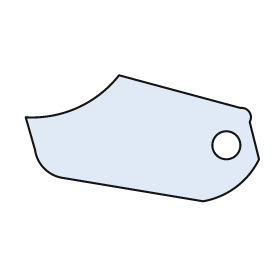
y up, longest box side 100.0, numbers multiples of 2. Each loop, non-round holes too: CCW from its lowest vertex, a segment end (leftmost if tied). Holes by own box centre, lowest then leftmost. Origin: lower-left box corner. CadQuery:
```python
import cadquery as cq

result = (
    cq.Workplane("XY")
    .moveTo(76.0, 0.0)
    .threePointArc((90.0, 6.0), (100.0, 18.0))
    .lineTo(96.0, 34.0)
    .threePointArc((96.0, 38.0), (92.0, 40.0))
    .lineTo(40.0, 54.0)
    .threePointArc((22.0, 40.0), (0.0, 36.0))
    .lineTo(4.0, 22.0)
    .threePointArc((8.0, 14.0), (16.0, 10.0))
    .close()
    .moveTo(86.0, 24.0)
    .circle(6.0)
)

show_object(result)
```